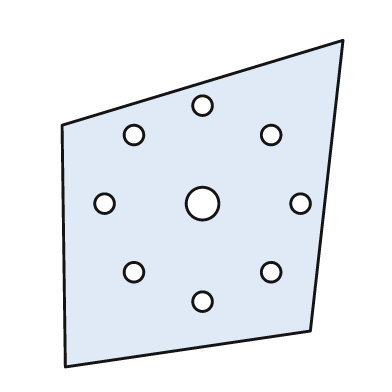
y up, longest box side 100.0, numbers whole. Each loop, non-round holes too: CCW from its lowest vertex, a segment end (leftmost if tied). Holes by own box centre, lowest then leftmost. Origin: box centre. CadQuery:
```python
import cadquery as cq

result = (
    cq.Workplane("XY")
    .moveTo(-42.0, -50.0)
    .lineTo(33.0, -39.0)
    .lineTo(43.0, 50.0)
    .lineTo(-43.0, 24.0)
    .close()
    .moveTo(0.0, -30.0)
    .circle(3.0)
    .moveTo(-21.0, -21.0)
    .circle(3.0)
    .moveTo(21.0, -21.0)
    .circle(3.0)
    .moveTo(-30.0, 0.0)
    .circle(3.0)
    .moveTo(0.0, 0.0)
    .circle(5.0)
    .moveTo(30.0, 0.0)
    .circle(3.0)
    .moveTo(-21.0, 21.0)
    .circle(3.0)
    .moveTo(21.0, 21.0)
    .circle(3.0)
    .moveTo(0.0, 30.0)
    .circle(3.0)
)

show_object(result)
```